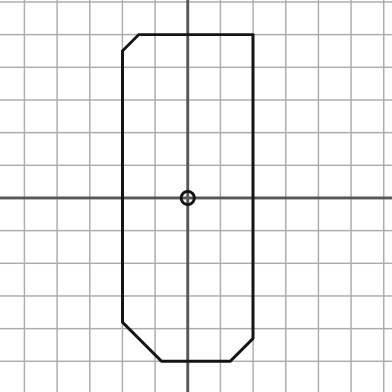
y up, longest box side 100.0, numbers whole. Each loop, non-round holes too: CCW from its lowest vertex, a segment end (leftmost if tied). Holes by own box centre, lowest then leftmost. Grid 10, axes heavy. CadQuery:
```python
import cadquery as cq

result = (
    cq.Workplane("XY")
    .moveTo(-8.0, -50.0)
    .lineTo(13.0, -50.0)
    .lineTo(20.0, -43.0)
    .lineTo(20.0, 50.0)
    .lineTo(-15.0, 50.0)
    .lineTo(-20.0, 45.0)
    .lineTo(-20.0, -38.0)
    .close()
    .moveTo(0.0, 0.0)
    .circle(2.0)
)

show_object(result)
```